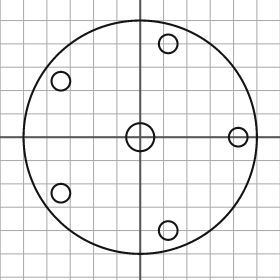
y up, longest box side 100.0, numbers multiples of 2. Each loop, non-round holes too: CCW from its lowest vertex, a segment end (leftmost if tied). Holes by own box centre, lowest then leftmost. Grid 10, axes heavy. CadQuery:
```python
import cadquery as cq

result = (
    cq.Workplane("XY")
    .moveTo(0.0, 0.0)
    .circle(50.0)
    .moveTo(12.0, -40.0)
    .circle(4.0)
    .moveTo(-34.0, -24.0)
    .circle(4.0)
    .moveTo(0.0, 0.0)
    .circle(6.0)
    .moveTo(42.0, 0.0)
    .circle(4.0)
    .moveTo(-34.0, 24.0)
    .circle(4.0)
    .moveTo(12.0, 40.0)
    .circle(4.0)
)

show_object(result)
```